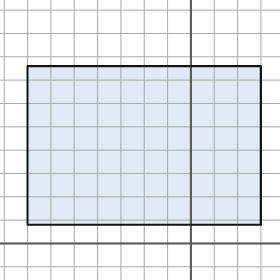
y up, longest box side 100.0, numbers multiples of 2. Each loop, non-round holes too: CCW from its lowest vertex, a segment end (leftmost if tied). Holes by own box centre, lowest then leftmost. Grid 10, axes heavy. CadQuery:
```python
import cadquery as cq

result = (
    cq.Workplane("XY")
    .moveTo(-70.0, 8.0)
    .lineTo(30.0, 8.0)
    .lineTo(30.0, 76.0)
    .lineTo(-70.0, 76.0)
    .close()
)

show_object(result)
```